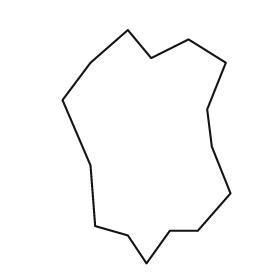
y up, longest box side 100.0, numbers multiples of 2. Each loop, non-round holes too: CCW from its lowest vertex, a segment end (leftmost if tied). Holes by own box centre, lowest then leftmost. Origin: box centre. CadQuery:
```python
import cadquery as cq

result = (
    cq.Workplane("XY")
    .moveTo(0.0, -50.0)
    .lineTo(10.0, -36.0)
    .lineTo(22.0, -36.0)
    .lineTo(36.0, -20.0)
    .lineTo(28.0, 0.0)
    .lineTo(26.0, 16.0)
    .lineTo(34.0, 36.0)
    .lineTo(18.0, 46.0)
    .lineTo(2.0, 38.0)
    .lineTo(-8.0, 50.0)
    .lineTo(-24.0, 36.0)
    .lineTo(-36.0, 20.0)
    .lineTo(-24.0, -8.0)
    .lineTo(-22.0, -34.0)
    .lineTo(-8.0, -38.0)
    .close()
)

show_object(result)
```